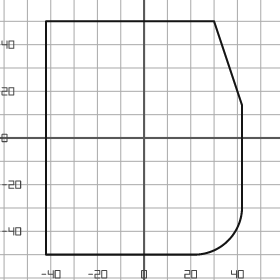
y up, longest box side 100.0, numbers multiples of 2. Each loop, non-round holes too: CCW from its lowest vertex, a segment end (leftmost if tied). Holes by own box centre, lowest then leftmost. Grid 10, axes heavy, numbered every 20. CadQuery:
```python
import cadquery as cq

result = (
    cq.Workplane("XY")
    .moveTo(-42.0, -50.0)
    .lineTo(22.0, -50.0)
    .threePointArc((36.0, -44.0), (42.0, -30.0))
    .lineTo(42.0, 14.0)
    .lineTo(30.0, 50.0)
    .lineTo(-42.0, 50.0)
    .close()
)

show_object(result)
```